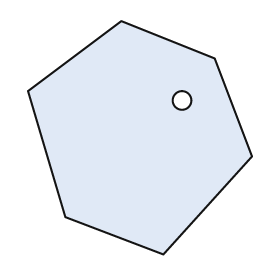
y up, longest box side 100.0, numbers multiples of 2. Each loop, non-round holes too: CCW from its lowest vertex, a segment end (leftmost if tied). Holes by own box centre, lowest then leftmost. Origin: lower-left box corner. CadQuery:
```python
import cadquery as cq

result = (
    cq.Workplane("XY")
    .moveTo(58.0, 0.0)
    .lineTo(96.0, 42.0)
    .lineTo(80.0, 84.0)
    .lineTo(40.0, 100.0)
    .lineTo(0.0, 70.0)
    .lineTo(16.0, 16.0)
    .close()
    .moveTo(66.0, 66.0)
    .circle(4.0)
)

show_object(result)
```